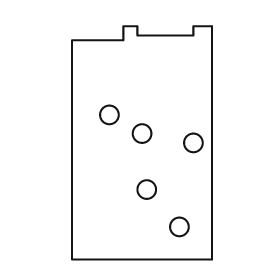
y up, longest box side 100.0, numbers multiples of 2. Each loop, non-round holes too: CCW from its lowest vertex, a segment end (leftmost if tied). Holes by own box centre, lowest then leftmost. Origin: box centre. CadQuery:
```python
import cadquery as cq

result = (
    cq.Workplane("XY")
    .moveTo(-30.0, -50.0)
    .lineTo(30.0, -50.0)
    .lineTo(30.0, 50.0)
    .lineTo(22.0, 50.0)
    .lineTo(22.0, 46.0)
    .lineTo(-2.0, 46.0)
    .lineTo(-2.0, 50.0)
    .lineTo(-8.0, 50.0)
    .lineTo(-8.0, 44.0)
    .lineTo(-30.0, 44.0)
    .close()
    .moveTo(16.0, -36.0)
    .circle(4.0)
    .moveTo(2.0, -20.0)
    .circle(4.0)
    .moveTo(22.0, 0.0)
    .circle(4.0)
    .moveTo(0.0, 4.0)
    .circle(4.0)
    .moveTo(-14.0, 12.0)
    .circle(4.0)
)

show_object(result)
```